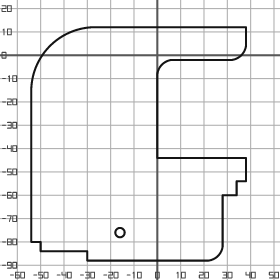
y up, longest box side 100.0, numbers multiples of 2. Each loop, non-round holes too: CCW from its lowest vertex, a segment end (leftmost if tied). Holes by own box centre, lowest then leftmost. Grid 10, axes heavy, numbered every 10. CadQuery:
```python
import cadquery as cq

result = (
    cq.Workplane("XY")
    .moveTo(-30.0, -88.0)
    .lineTo(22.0, -88.0)
    .threePointArc((26.0, -86.0), (28.0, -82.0))
    .lineTo(28.0, -60.0)
    .lineTo(34.0, -60.0)
    .lineTo(34.0, -54.0)
    .lineTo(38.0, -54.0)
    .lineTo(38.0, -44.0)
    .lineTo(0.0, -44.0)
    .lineTo(0.0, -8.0)
    .threePointArc((2.0, -4.0), (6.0, -2.0))
    .lineTo(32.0, -2.0)
    .threePointArc((36.0, 0.0), (38.0, 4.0))
    .lineTo(38.0, 12.0)
    .lineTo(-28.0, 12.0)
    .threePointArc((-46.0, 4.0), (-54.0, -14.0))
    .lineTo(-54.0, -80.0)
    .lineTo(-50.0, -80.0)
    .lineTo(-50.0, -84.0)
    .lineTo(-30.0, -84.0)
    .close()
    .moveTo(-16.0, -76.0)
    .circle(2.0)
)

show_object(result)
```